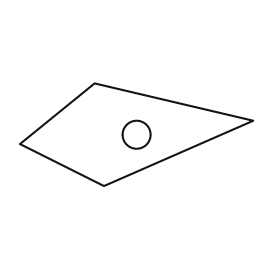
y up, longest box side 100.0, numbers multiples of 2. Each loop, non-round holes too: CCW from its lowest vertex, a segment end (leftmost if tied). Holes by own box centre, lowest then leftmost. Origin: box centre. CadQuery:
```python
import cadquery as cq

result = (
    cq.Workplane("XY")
    .moveTo(-14.0, -22.0)
    .lineTo(50.0, 6.0)
    .lineTo(-18.0, 22.0)
    .lineTo(-50.0, -4.0)
    .close()
    .moveTo(0.0, 0.0)
    .circle(6.0)
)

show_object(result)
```